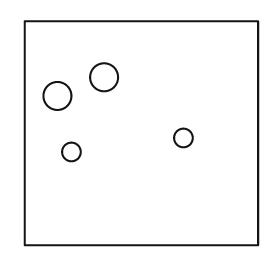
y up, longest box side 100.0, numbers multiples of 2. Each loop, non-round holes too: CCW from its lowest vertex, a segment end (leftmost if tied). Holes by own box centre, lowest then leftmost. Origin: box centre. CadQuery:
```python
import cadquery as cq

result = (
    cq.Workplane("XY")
    .moveTo(-50.0, -48.0)
    .lineTo(50.0, -48.0)
    .lineTo(50.0, 48.0)
    .lineTo(-50.0, 48.0)
    .close()
    .moveTo(-30.0, -8.0)
    .circle(4.0)
    .moveTo(18.0, -2.0)
    .circle(4.0)
    .moveTo(-36.0, 16.0)
    .circle(6.0)
    .moveTo(-16.0, 24.0)
    .circle(6.0)
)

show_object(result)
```